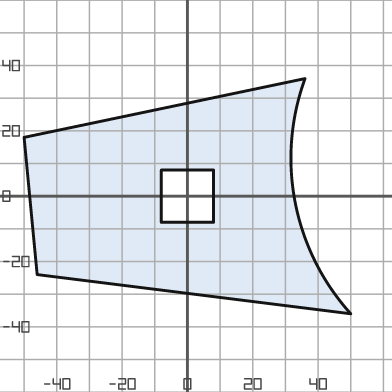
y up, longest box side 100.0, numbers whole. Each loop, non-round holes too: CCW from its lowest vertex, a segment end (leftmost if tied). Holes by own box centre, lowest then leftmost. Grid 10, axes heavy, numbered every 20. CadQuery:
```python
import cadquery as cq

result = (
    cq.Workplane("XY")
    .moveTo(50.0, -36.0)
    .threePointArc((33.0, -2.0), (36.0, 36.0))
    .lineTo(-50.0, 18.0)
    .lineTo(-46.0, -24.0)
    .close()
    .moveTo(-8.0, -8.0)
    .lineTo(8.0, -8.0)
    .lineTo(8.0, 8.0)
    .lineTo(-8.0, 8.0)
    .close()
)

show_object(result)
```